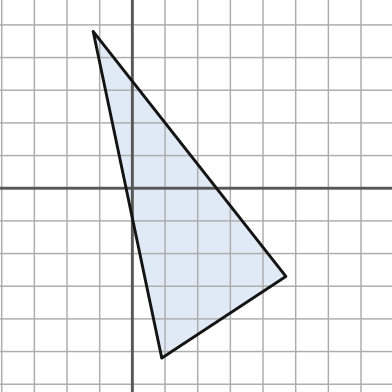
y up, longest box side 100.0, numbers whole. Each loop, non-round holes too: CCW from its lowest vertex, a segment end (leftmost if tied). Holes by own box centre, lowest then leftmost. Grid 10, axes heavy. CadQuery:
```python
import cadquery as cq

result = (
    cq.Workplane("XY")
    .moveTo(9.0, -52.0)
    .lineTo(47.0, -27.0)
    .lineTo(-12.0, 48.0)
    .close()
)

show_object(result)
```